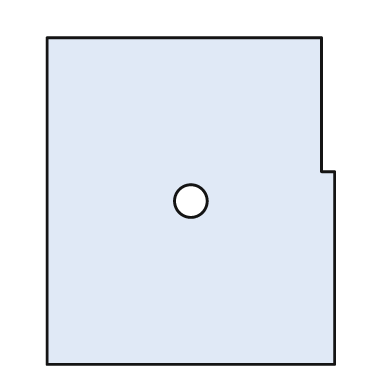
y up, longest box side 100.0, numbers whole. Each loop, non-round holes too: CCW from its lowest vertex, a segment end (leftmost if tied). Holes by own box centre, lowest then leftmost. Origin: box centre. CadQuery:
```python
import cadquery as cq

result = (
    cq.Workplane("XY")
    .moveTo(-44.0, -50.0)
    .lineTo(44.0, -50.0)
    .lineTo(44.0, 9.0)
    .lineTo(40.0, 9.0)
    .lineTo(40.0, 50.0)
    .lineTo(-44.0, 50.0)
    .close()
    .moveTo(0.0, 0.0)
    .circle(5.0)
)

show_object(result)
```